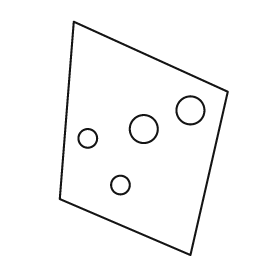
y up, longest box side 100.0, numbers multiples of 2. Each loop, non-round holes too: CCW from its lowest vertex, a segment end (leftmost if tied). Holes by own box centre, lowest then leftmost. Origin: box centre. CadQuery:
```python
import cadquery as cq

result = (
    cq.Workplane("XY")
    .moveTo(20.0, -50.0)
    .lineTo(36.0, 20.0)
    .lineTo(-30.0, 50.0)
    .lineTo(-36.0, -26.0)
    .close()
    .moveTo(-10.0, -20.0)
    .circle(4.0)
    .moveTo(-24.0, 0.0)
    .circle(4.0)
    .moveTo(0.0, 4.0)
    .circle(6.0)
    .moveTo(20.0, 12.0)
    .circle(6.0)
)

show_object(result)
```